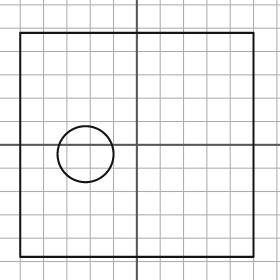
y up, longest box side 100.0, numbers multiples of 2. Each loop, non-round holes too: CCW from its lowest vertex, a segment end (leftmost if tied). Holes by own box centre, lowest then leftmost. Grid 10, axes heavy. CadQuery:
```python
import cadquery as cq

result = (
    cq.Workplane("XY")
    .moveTo(-50.0, -48.0)
    .lineTo(50.0, -48.0)
    .lineTo(50.0, 48.0)
    .lineTo(-50.0, 48.0)
    .close()
    .moveTo(-22.0, -4.0)
    .circle(12.0)
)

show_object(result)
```